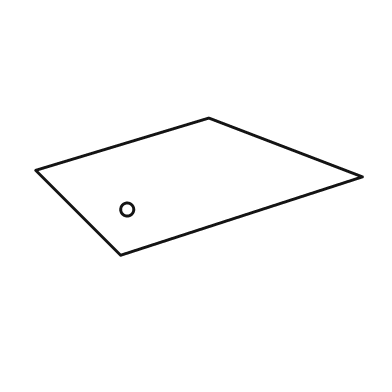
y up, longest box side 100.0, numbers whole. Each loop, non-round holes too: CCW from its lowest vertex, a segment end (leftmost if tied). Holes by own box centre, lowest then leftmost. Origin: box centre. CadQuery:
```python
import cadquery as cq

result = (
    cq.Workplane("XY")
    .moveTo(-24.0, -21.0)
    .lineTo(50.0, 3.0)
    .lineTo(3.0, 21.0)
    .lineTo(-50.0, 5.0)
    .close()
    .moveTo(-22.0, -7.0)
    .circle(2.0)
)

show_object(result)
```